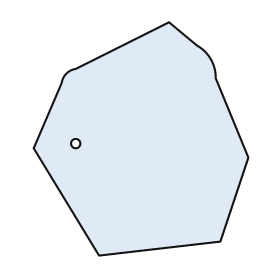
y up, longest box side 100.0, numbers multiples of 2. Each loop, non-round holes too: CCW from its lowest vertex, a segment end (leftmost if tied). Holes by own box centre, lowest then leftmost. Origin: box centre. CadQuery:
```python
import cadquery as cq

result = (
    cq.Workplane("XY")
    .moveTo(-18.0, -50.0)
    .lineTo(34.0, -44.0)
    .lineTo(46.0, -8.0)
    .lineTo(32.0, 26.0)
    .threePointArc((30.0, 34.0), (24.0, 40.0))
    .lineTo(12.0, 50.0)
    .lineTo(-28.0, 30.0)
    .threePointArc((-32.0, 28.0), (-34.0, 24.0))
    .lineTo(-46.0, -4.0)
    .close()
    .moveTo(-28.0, -2.0)
    .circle(2.0)
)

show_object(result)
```